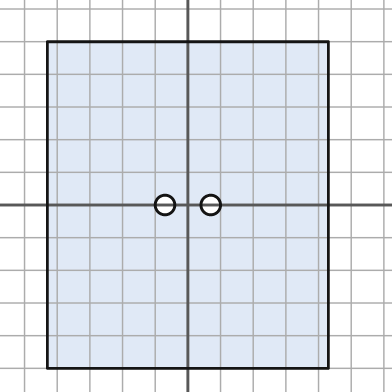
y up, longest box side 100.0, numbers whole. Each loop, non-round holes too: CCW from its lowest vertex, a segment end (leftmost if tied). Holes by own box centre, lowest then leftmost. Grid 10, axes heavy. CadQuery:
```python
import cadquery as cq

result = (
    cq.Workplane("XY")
    .moveTo(-43.0, -50.0)
    .lineTo(43.0, -50.0)
    .lineTo(43.0, 50.0)
    .lineTo(-43.0, 50.0)
    .close()
    .moveTo(-7.0, 0.0)
    .circle(3.0)
    .moveTo(7.0, 0.0)
    .circle(3.0)
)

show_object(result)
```